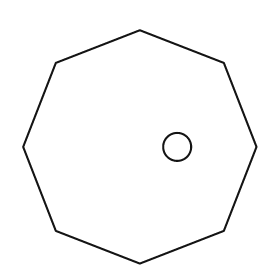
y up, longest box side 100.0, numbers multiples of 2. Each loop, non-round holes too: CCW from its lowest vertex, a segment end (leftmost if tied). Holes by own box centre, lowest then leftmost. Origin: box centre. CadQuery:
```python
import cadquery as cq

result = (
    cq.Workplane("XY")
    .moveTo(0.0, -50.0)
    .lineTo(36.0, -36.0)
    .lineTo(50.0, 0.0)
    .lineTo(36.0, 36.0)
    .lineTo(0.0, 50.0)
    .lineTo(-36.0, 36.0)
    .lineTo(-50.0, 0.0)
    .lineTo(-36.0, -36.0)
    .close()
    .moveTo(16.0, 0.0)
    .circle(6.0)
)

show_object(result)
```